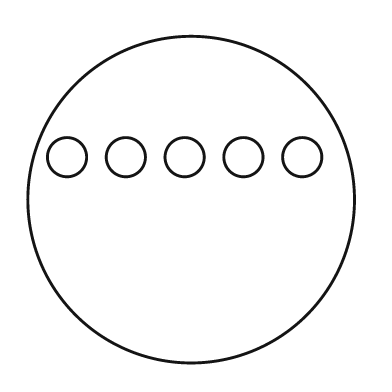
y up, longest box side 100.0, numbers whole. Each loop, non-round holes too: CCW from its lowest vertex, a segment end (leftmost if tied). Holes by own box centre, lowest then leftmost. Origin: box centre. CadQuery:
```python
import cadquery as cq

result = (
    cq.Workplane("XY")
    .moveTo(0.0, 0.0)
    .circle(50.0)
    .moveTo(-38.0, 13.0)
    .circle(6.0)
    .moveTo(-20.0, 13.0)
    .circle(6.0)
    .moveTo(-2.0, 13.0)
    .circle(6.0)
    .moveTo(16.0, 13.0)
    .circle(6.0)
    .moveTo(34.0, 13.0)
    .circle(6.0)
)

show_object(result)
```